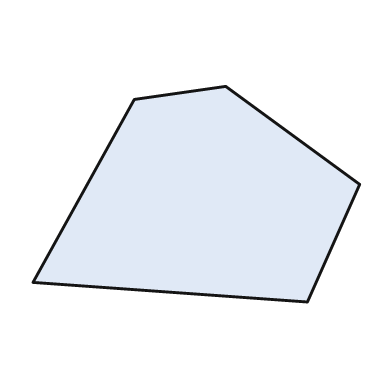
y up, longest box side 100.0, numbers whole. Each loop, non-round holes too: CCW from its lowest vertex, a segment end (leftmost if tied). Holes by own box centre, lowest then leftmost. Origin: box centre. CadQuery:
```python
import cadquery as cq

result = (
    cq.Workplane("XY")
    .moveTo(34.0, -33.0)
    .lineTo(50.0, 3.0)
    .lineTo(9.0, 33.0)
    .lineTo(-19.0, 29.0)
    .lineTo(-50.0, -27.0)
    .close()
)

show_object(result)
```